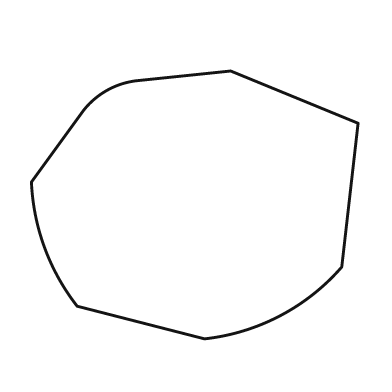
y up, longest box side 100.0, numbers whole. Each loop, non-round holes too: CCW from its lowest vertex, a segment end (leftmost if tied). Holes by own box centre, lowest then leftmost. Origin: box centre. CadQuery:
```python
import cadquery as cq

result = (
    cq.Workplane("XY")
    .moveTo(3.0, -41.0)
    .threePointArc((26.0, -34.0), (45.0, -19.0))
    .lineTo(50.0, 25.0)
    .lineTo(11.0, 41.0)
    .lineTo(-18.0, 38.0)
    .threePointArc((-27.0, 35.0), (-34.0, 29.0))
    .lineTo(-50.0, 7.0)
    .threePointArc((-46.0, -13.0), (-36.0, -31.0))
    .close()
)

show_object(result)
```